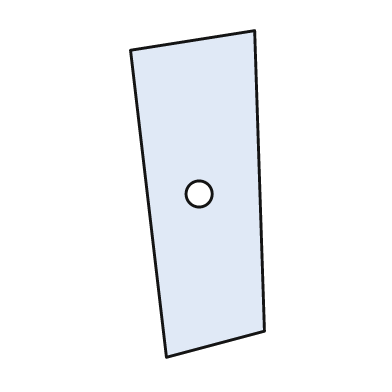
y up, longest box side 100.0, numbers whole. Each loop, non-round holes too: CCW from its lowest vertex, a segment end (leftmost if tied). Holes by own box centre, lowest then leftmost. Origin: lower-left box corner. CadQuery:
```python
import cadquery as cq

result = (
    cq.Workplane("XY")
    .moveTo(11.0, 0.0)
    .lineTo(41.0, 8.0)
    .lineTo(38.0, 100.0)
    .lineTo(0.0, 94.0)
    .close()
    .moveTo(21.0, 50.0)
    .circle(4.0)
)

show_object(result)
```